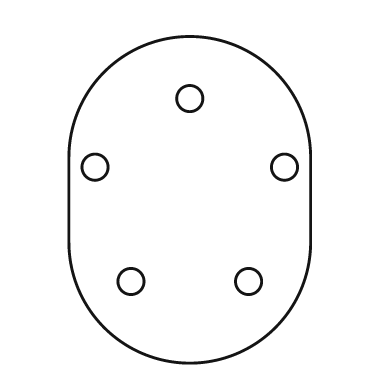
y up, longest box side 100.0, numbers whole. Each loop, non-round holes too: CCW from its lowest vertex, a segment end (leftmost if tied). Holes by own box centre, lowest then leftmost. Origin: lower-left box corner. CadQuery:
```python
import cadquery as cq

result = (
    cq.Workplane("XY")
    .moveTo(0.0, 37.0)
    .threePointArc((37.0, 0.0), (74.0, 37.0))
    .lineTo(74.0, 63.0)
    .threePointArc((37.0, 100.0), (0.0, 63.0))
    .close()
    .moveTo(19.0, 25.0)
    .circle(4.0)
    .moveTo(55.0, 25.0)
    .circle(4.0)
    .moveTo(8.0, 60.0)
    .circle(4.0)
    .moveTo(66.0, 60.0)
    .circle(4.0)
    .moveTo(37.0, 81.0)
    .circle(4.0)
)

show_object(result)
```